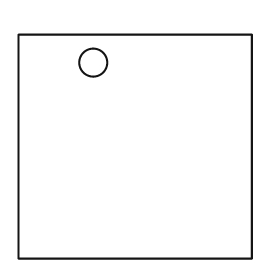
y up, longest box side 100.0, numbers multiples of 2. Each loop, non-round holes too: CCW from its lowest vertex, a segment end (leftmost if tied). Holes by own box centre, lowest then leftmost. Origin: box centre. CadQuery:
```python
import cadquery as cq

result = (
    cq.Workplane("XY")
    .moveTo(-50.0, -48.0)
    .lineTo(50.0, -48.0)
    .lineTo(50.0, 48.0)
    .lineTo(-50.0, 48.0)
    .close()
    .moveTo(-18.0, 36.0)
    .circle(6.0)
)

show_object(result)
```